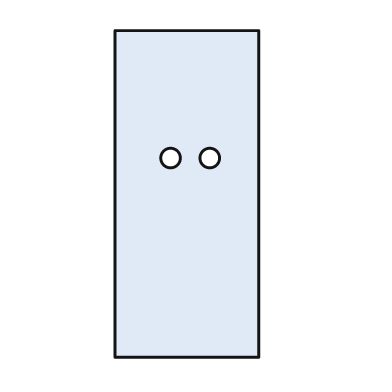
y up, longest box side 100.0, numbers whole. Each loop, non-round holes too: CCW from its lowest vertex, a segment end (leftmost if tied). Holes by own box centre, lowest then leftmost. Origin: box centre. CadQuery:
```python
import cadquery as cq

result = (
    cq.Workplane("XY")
    .moveTo(-22.0, -50.0)
    .lineTo(22.0, -50.0)
    .lineTo(22.0, 50.0)
    .lineTo(-22.0, 50.0)
    .close()
    .moveTo(-5.0, 11.0)
    .circle(3.0)
    .moveTo(7.0, 11.0)
    .circle(3.0)
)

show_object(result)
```